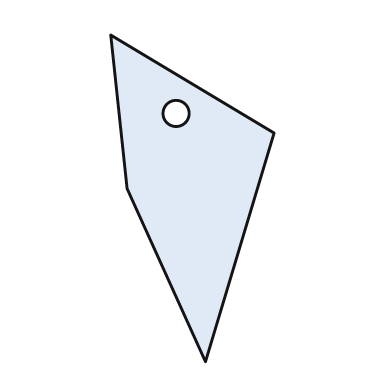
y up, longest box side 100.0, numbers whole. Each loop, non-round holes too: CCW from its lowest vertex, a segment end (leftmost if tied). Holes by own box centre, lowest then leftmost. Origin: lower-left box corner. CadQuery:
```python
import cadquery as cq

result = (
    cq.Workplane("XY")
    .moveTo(29.0, 0.0)
    .lineTo(50.0, 70.0)
    .lineTo(0.0, 100.0)
    .lineTo(5.0, 53.0)
    .close()
    .moveTo(20.0, 76.0)
    .circle(4.0)
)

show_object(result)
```